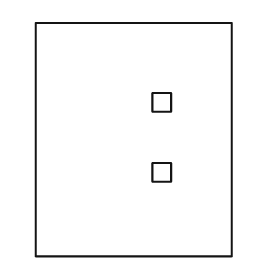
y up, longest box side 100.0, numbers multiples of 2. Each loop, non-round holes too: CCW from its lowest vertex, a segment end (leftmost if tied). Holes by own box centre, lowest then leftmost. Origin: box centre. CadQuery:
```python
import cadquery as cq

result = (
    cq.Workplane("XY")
    .moveTo(-42.0, -50.0)
    .lineTo(42.0, -50.0)
    .lineTo(42.0, 50.0)
    .lineTo(-42.0, 50.0)
    .close()
    .moveTo(8.0, -18.0)
    .lineTo(16.0, -18.0)
    .lineTo(16.0, -10.0)
    .lineTo(8.0, -10.0)
    .close()
    .moveTo(8.0, 12.0)
    .lineTo(16.0, 12.0)
    .lineTo(16.0, 20.0)
    .lineTo(8.0, 20.0)
    .close()
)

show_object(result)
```